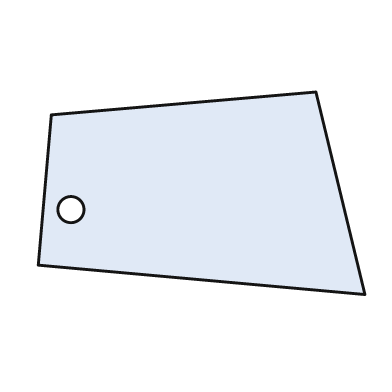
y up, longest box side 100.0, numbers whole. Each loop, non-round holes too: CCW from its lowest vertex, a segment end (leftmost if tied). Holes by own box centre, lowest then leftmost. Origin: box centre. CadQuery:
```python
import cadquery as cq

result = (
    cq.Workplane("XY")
    .moveTo(50.0, -31.0)
    .lineTo(35.0, 31.0)
    .lineTo(-46.0, 24.0)
    .lineTo(-50.0, -22.0)
    .close()
    .moveTo(-40.0, -5.0)
    .circle(4.0)
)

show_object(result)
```